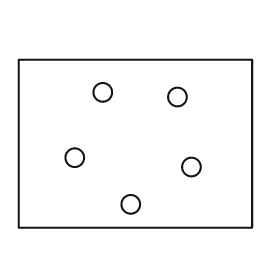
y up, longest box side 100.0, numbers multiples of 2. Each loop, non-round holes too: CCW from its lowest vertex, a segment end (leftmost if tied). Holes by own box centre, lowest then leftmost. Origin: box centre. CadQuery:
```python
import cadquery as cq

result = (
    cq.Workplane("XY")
    .moveTo(-50.0, -36.0)
    .lineTo(50.0, -36.0)
    .lineTo(50.0, 36.0)
    .lineTo(-50.0, 36.0)
    .close()
    .moveTo(-2.0, -26.0)
    .circle(4.0)
    .moveTo(24.0, -10.0)
    .circle(4.0)
    .moveTo(-26.0, -6.0)
    .circle(4.0)
    .moveTo(18.0, 20.0)
    .circle(4.0)
    .moveTo(-14.0, 22.0)
    .circle(4.0)
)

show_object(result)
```